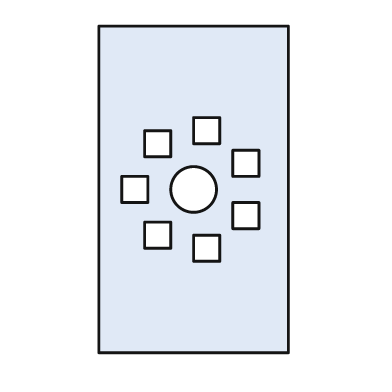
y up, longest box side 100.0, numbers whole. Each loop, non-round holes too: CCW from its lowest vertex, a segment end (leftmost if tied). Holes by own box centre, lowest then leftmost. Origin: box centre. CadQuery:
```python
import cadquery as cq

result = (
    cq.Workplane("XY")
    .moveTo(-29.0, -50.0)
    .lineTo(29.0, -50.0)
    .lineTo(29.0, 50.0)
    .lineTo(-29.0, 50.0)
    .close()
    .moveTo(0.0, -22.0)
    .lineTo(8.0, -22.0)
    .lineTo(8.0, -14.0)
    .lineTo(0.0, -14.0)
    .close()
    .moveTo(-15.0, -18.0)
    .lineTo(-7.0, -18.0)
    .lineTo(-7.0, -10.0)
    .lineTo(-15.0, -10.0)
    .close()
    .moveTo(12.0, -12.0)
    .lineTo(20.0, -12.0)
    .lineTo(20.0, -4.0)
    .lineTo(12.0, -4.0)
    .close()
    .moveTo(-22.0, -4.0)
    .lineTo(-14.0, -4.0)
    .lineTo(-14.0, 4.0)
    .lineTo(-22.0, 4.0)
    .close()
    .moveTo(0.0, 0.0)
    .circle(7.0)
    .moveTo(12.0, 4.0)
    .lineTo(20.0, 4.0)
    .lineTo(20.0, 12.0)
    .lineTo(12.0, 12.0)
    .close()
    .moveTo(-15.0, 10.0)
    .lineTo(-7.0, 10.0)
    .lineTo(-7.0, 18.0)
    .lineTo(-15.0, 18.0)
    .close()
    .moveTo(0.0, 14.0)
    .lineTo(8.0, 14.0)
    .lineTo(8.0, 22.0)
    .lineTo(0.0, 22.0)
    .close()
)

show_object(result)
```